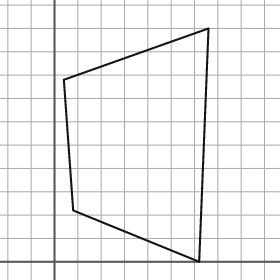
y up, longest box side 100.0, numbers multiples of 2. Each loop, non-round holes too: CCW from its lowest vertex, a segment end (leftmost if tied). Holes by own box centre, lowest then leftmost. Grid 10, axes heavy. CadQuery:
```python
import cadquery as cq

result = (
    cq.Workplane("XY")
    .moveTo(62.0, 0.0)
    .lineTo(66.0, 100.0)
    .lineTo(4.0, 78.0)
    .lineTo(8.0, 22.0)
    .close()
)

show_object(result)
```